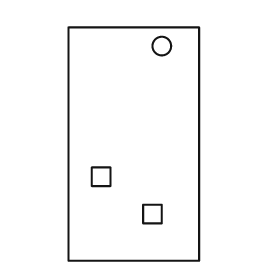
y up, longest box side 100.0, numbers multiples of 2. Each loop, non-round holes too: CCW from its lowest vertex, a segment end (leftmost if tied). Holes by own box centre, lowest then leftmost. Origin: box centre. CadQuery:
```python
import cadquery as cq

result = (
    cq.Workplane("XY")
    .moveTo(-28.0, -50.0)
    .lineTo(28.0, -50.0)
    .lineTo(28.0, 50.0)
    .lineTo(-28.0, 50.0)
    .close()
    .moveTo(4.0, -34.0)
    .lineTo(12.0, -34.0)
    .lineTo(12.0, -26.0)
    .lineTo(4.0, -26.0)
    .close()
    .moveTo(-18.0, -18.0)
    .lineTo(-10.0, -18.0)
    .lineTo(-10.0, -10.0)
    .lineTo(-18.0, -10.0)
    .close()
    .moveTo(12.0, 42.0)
    .circle(4.0)
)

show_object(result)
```